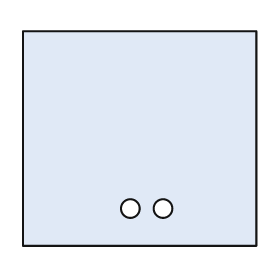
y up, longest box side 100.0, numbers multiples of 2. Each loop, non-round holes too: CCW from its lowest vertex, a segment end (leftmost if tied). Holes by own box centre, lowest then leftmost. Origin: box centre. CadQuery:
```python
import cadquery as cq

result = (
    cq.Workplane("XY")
    .moveTo(-50.0, -46.0)
    .lineTo(50.0, -46.0)
    .lineTo(50.0, 46.0)
    .lineTo(-50.0, 46.0)
    .close()
    .moveTo(-4.0, -30.0)
    .circle(4.0)
    .moveTo(10.0, -30.0)
    .circle(4.0)
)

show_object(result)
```